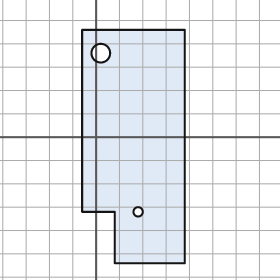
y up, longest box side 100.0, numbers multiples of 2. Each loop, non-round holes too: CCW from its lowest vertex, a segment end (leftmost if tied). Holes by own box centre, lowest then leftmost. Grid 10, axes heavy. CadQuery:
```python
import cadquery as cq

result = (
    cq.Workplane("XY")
    .moveTo(8.0, -54.0)
    .lineTo(38.0, -54.0)
    .lineTo(38.0, 46.0)
    .lineTo(-6.0, 46.0)
    .lineTo(-6.0, -32.0)
    .lineTo(8.0, -32.0)
    .close()
    .moveTo(18.0, -32.0)
    .circle(2.0)
    .moveTo(2.0, 36.0)
    .circle(4.0)
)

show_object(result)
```